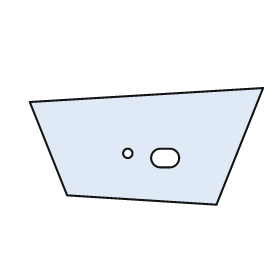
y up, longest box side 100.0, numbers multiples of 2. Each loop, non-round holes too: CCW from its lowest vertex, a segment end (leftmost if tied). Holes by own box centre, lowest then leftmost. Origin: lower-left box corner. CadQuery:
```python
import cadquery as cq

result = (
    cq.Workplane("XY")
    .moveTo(80.0, 0.0)
    .lineTo(100.0, 50.0)
    .lineTo(0.0, 44.0)
    .lineTo(16.0, 4.0)
    .close()
    .moveTo(56.0, 16.0)
    .lineTo(60.0, 16.0)
    .threePointArc((64.0, 20.0), (60.0, 24.0))
    .lineTo(56.0, 24.0)
    .threePointArc((52.0, 20.0), (56.0, 16.0))
    .close()
    .moveTo(42.0, 22.0)
    .circle(2.0)
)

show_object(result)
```